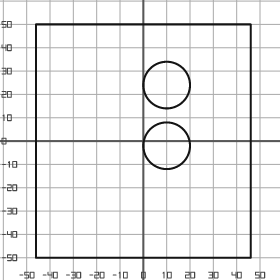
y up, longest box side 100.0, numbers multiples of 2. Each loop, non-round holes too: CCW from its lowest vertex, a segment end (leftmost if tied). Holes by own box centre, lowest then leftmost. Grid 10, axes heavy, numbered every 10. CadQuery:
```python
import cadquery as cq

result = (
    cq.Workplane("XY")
    .moveTo(-46.0, -50.0)
    .lineTo(46.0, -50.0)
    .lineTo(46.0, 50.0)
    .lineTo(-46.0, 50.0)
    .close()
    .moveTo(10.0, -2.0)
    .circle(10.0)
    .moveTo(10.0, 24.0)
    .circle(10.0)
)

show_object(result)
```